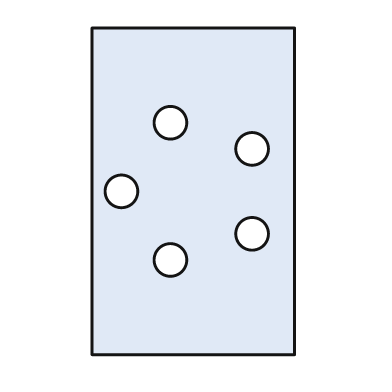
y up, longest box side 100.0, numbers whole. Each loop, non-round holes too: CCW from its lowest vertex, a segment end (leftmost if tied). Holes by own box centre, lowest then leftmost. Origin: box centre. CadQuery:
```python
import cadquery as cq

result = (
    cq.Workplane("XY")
    .moveTo(-31.0, -50.0)
    .lineTo(31.0, -50.0)
    .lineTo(31.0, 50.0)
    .lineTo(-31.0, 50.0)
    .close()
    .moveTo(-7.0, -21.0)
    .circle(5.0)
    .moveTo(18.0, -13.0)
    .circle(5.0)
    .moveTo(-22.0, 0.0)
    .circle(5.0)
    .moveTo(18.0, 13.0)
    .circle(5.0)
    .moveTo(-7.0, 21.0)
    .circle(5.0)
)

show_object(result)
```